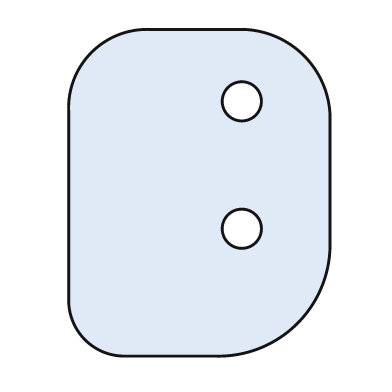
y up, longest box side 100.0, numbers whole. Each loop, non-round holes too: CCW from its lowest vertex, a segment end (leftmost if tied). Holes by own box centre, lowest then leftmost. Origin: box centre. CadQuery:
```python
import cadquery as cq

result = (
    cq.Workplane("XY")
    .moveTo(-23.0, -50.0)
    .lineTo(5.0, -50.0)
    .threePointArc((30.0, -40.0), (40.0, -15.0))
    .lineTo(40.0, 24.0)
    .threePointArc((32.0, 42.0), (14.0, 50.0))
    .lineTo(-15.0, 50.0)
    .threePointArc((-33.0, 43.0), (-40.0, 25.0))
    .lineTo(-40.0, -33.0)
    .threePointArc((-35.0, -45.0), (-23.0, -50.0))
    .close()
    .moveTo(13.0, -11.0)
    .circle(6.0)
    .moveTo(13.0, 28.0)
    .circle(6.0)
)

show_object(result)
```